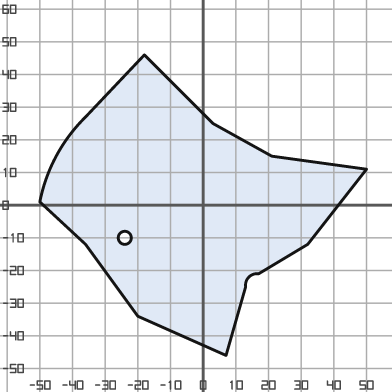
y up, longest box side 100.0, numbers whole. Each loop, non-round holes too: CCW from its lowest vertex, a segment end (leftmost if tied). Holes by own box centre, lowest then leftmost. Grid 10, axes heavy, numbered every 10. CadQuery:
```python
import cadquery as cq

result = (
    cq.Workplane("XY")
    .moveTo(7.0, -46.0)
    .lineTo(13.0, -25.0)
    .threePointArc((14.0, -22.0), (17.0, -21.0))
    .lineTo(32.0, -12.0)
    .lineTo(50.0, 11.0)
    .lineTo(21.0, 15.0)
    .lineTo(3.0, 25.0)
    .lineTo(-18.0, 46.0)
    .lineTo(-36.0, 27.0)
    .threePointArc((-45.0, 15.0), (-50.0, 1.0))
    .lineTo(-36.0, -12.0)
    .lineTo(-20.0, -34.0)
    .close()
    .moveTo(-24.0, -10.0)
    .circle(2.0)
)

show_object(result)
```